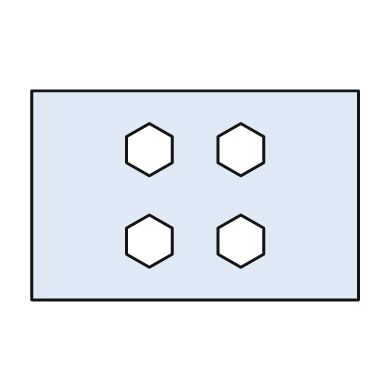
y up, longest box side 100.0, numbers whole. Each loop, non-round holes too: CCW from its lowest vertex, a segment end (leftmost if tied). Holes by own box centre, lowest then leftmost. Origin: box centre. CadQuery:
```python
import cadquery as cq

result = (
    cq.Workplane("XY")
    .moveTo(-50.0, -32.0)
    .lineTo(50.0, -32.0)
    .lineTo(50.0, 32.0)
    .lineTo(-50.0, 32.0)
    .close()
    .moveTo(-14.0, -22.0)
    .lineTo(-7.0, -18.0)
    .lineTo(-7.0, -10.0)
    .lineTo(-14.0, -6.0)
    .lineTo(-21.0, -10.0)
    .lineTo(-21.0, -18.0)
    .close()
    .moveTo(14.0, -22.0)
    .lineTo(21.0, -18.0)
    .lineTo(21.0, -10.0)
    .lineTo(14.0, -6.0)
    .lineTo(7.0, -10.0)
    .lineTo(7.0, -18.0)
    .close()
    .moveTo(-14.0, 6.0)
    .lineTo(-7.0, 10.0)
    .lineTo(-7.0, 18.0)
    .lineTo(-14.0, 22.0)
    .lineTo(-21.0, 18.0)
    .lineTo(-21.0, 10.0)
    .close()
    .moveTo(14.0, 6.0)
    .lineTo(21.0, 10.0)
    .lineTo(21.0, 18.0)
    .lineTo(14.0, 22.0)
    .lineTo(7.0, 18.0)
    .lineTo(7.0, 10.0)
    .close()
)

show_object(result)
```